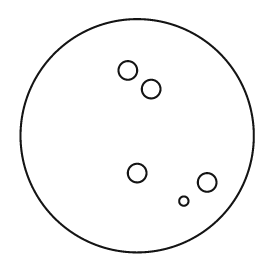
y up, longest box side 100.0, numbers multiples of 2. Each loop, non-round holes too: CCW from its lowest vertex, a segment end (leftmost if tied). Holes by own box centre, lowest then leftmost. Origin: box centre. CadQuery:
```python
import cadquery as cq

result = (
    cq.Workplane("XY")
    .moveTo(0.0, 0.0)
    .circle(50.0)
    .moveTo(20.0, -28.0)
    .circle(2.0)
    .moveTo(30.0, -20.0)
    .circle(4.0)
    .moveTo(0.0, -16.0)
    .circle(4.0)
    .moveTo(6.0, 20.0)
    .circle(4.0)
    .moveTo(-4.0, 28.0)
    .circle(4.0)
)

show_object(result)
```